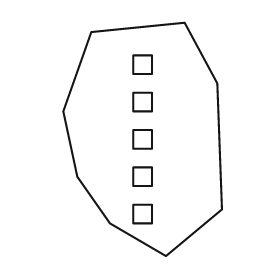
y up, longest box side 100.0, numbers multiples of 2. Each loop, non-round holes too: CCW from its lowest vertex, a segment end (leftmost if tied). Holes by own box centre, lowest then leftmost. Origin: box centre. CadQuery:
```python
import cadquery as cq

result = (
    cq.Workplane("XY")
    .moveTo(10.0, -50.0)
    .lineTo(34.0, -30.0)
    .lineTo(32.0, 24.0)
    .lineTo(18.0, 50.0)
    .lineTo(-22.0, 46.0)
    .lineTo(-34.0, 12.0)
    .lineTo(-28.0, -16.0)
    .lineTo(-14.0, -36.0)
    .close()
    .moveTo(-4.0, -36.0)
    .lineTo(4.0, -36.0)
    .lineTo(4.0, -28.0)
    .lineTo(-4.0, -28.0)
    .close()
    .moveTo(-4.0, -20.0)
    .lineTo(4.0, -20.0)
    .lineTo(4.0, -12.0)
    .lineTo(-4.0, -12.0)
    .close()
    .moveTo(-4.0, -4.0)
    .lineTo(4.0, -4.0)
    .lineTo(4.0, 4.0)
    .lineTo(-4.0, 4.0)
    .close()
    .moveTo(-4.0, 12.0)
    .lineTo(4.0, 12.0)
    .lineTo(4.0, 20.0)
    .lineTo(-4.0, 20.0)
    .close()
    .moveTo(-4.0, 28.0)
    .lineTo(4.0, 28.0)
    .lineTo(4.0, 36.0)
    .lineTo(-4.0, 36.0)
    .close()
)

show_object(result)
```